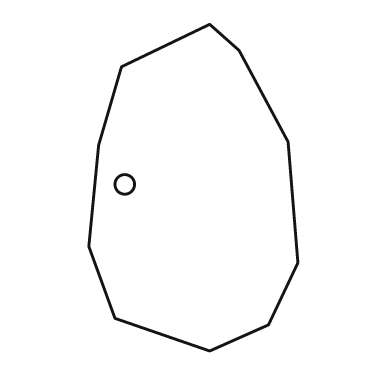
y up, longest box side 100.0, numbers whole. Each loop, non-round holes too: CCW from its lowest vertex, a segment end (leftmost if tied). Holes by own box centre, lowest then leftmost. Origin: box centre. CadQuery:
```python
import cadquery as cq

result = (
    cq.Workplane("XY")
    .moveTo(5.0, -50.0)
    .lineTo(23.0, -42.0)
    .lineTo(32.0, -23.0)
    .lineTo(29.0, 14.0)
    .lineTo(14.0, 42.0)
    .lineTo(5.0, 50.0)
    .lineTo(-22.0, 37.0)
    .lineTo(-29.0, 13.0)
    .lineTo(-32.0, -18.0)
    .lineTo(-24.0, -40.0)
    .close()
    .moveTo(-21.0, 1.0)
    .circle(3.0)
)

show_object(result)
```